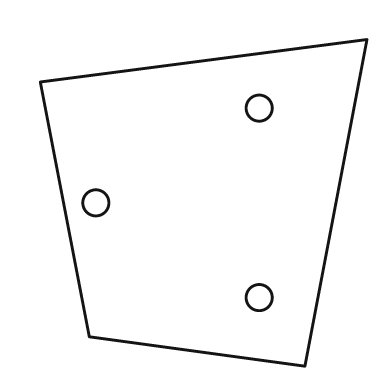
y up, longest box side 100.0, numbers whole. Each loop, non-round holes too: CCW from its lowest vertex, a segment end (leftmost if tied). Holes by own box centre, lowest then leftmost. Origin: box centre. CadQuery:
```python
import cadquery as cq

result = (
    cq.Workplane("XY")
    .moveTo(31.0, -50.0)
    .lineTo(50.0, 50.0)
    .lineTo(-50.0, 37.0)
    .lineTo(-35.0, -41.0)
    .close()
    .moveTo(17.0, -29.0)
    .circle(4.0)
    .moveTo(-33.0, 0.0)
    .circle(4.0)
    .moveTo(17.0, 29.0)
    .circle(4.0)
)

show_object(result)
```